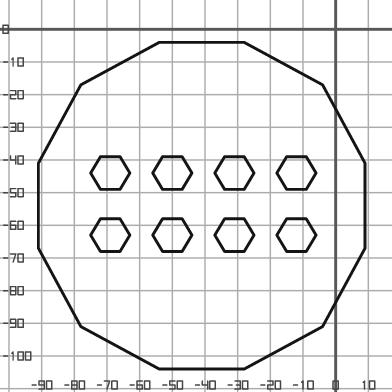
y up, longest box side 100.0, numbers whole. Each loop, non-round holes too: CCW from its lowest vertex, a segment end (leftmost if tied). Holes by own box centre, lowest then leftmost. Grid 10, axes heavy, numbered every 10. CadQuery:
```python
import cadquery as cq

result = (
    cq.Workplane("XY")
    .moveTo(-54.0, -104.0)
    .lineTo(-28.0, -104.0)
    .lineTo(-4.0, -91.0)
    .lineTo(9.0, -67.0)
    .lineTo(9.0, -41.0)
    .lineTo(-4.0, -17.0)
    .lineTo(-28.0, -4.0)
    .lineTo(-54.0, -4.0)
    .lineTo(-78.0, -17.0)
    .lineTo(-91.0, -41.0)
    .lineTo(-91.0, -67.0)
    .lineTo(-78.0, -91.0)
    .close()
    .moveTo(-72.0, -68.0)
    .lineTo(-66.0, -68.0)
    .lineTo(-63.0, -63.0)
    .lineTo(-66.0, -58.0)
    .lineTo(-72.0, -58.0)
    .lineTo(-75.0, -63.0)
    .close()
    .moveTo(-53.0, -68.0)
    .lineTo(-47.0, -68.0)
    .lineTo(-44.0, -63.0)
    .lineTo(-47.0, -58.0)
    .lineTo(-53.0, -58.0)
    .lineTo(-56.0, -63.0)
    .close()
    .moveTo(-34.0, -68.0)
    .lineTo(-28.0, -68.0)
    .lineTo(-25.0, -63.0)
    .lineTo(-28.0, -58.0)
    .lineTo(-34.0, -58.0)
    .lineTo(-37.0, -63.0)
    .close()
    .moveTo(-15.0, -68.0)
    .lineTo(-9.0, -68.0)
    .lineTo(-6.0, -63.0)
    .lineTo(-9.0, -58.0)
    .lineTo(-15.0, -58.0)
    .lineTo(-18.0, -63.0)
    .close()
    .moveTo(-72.0, -49.0)
    .lineTo(-66.0, -49.0)
    .lineTo(-63.0, -44.0)
    .lineTo(-66.0, -39.0)
    .lineTo(-72.0, -39.0)
    .lineTo(-75.0, -44.0)
    .close()
    .moveTo(-53.0, -49.0)
    .lineTo(-47.0, -49.0)
    .lineTo(-44.0, -44.0)
    .lineTo(-47.0, -39.0)
    .lineTo(-53.0, -39.0)
    .lineTo(-56.0, -44.0)
    .close()
    .moveTo(-34.0, -49.0)
    .lineTo(-28.0, -49.0)
    .lineTo(-25.0, -44.0)
    .lineTo(-28.0, -39.0)
    .lineTo(-34.0, -39.0)
    .lineTo(-37.0, -44.0)
    .close()
    .moveTo(-15.0, -49.0)
    .lineTo(-9.0, -49.0)
    .lineTo(-6.0, -44.0)
    .lineTo(-9.0, -39.0)
    .lineTo(-15.0, -39.0)
    .lineTo(-18.0, -44.0)
    .close()
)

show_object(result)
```